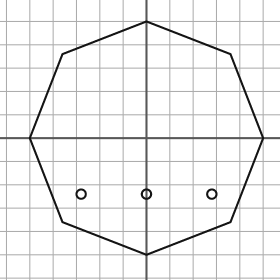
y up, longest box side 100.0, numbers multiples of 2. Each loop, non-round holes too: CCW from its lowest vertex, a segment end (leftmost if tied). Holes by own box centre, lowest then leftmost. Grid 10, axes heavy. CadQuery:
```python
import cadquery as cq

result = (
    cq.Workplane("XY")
    .moveTo(0.0, -50.0)
    .lineTo(36.0, -36.0)
    .lineTo(50.0, 0.0)
    .lineTo(36.0, 36.0)
    .lineTo(0.0, 50.0)
    .lineTo(-36.0, 36.0)
    .lineTo(-50.0, 0.0)
    .lineTo(-36.0, -36.0)
    .close()
    .moveTo(-28.0, -24.0)
    .circle(2.0)
    .moveTo(0.0, -24.0)
    .circle(2.0)
    .moveTo(28.0, -24.0)
    .circle(2.0)
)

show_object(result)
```